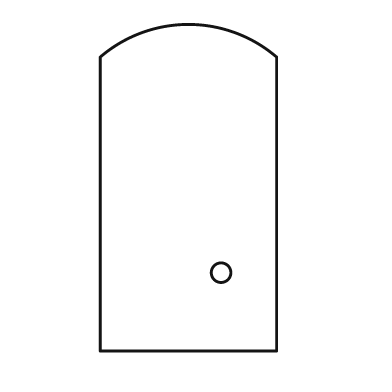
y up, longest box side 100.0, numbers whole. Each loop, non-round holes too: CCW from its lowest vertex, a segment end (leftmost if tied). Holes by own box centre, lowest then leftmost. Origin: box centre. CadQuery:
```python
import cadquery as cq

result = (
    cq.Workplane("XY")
    .moveTo(-27.0, -50.0)
    .lineTo(27.0, -50.0)
    .lineTo(27.0, 40.0)
    .threePointArc((0.0, 50.0), (-27.0, 40.0))
    .close()
    .moveTo(10.0, -26.0)
    .circle(3.0)
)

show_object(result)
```